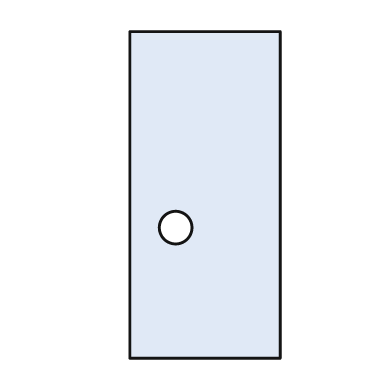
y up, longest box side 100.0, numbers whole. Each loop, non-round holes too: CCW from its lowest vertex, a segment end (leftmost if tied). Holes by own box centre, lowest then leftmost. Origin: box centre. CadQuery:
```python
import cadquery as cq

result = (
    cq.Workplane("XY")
    .moveTo(-23.0, -50.0)
    .lineTo(23.0, -50.0)
    .lineTo(23.0, 50.0)
    .lineTo(-23.0, 50.0)
    .close()
    .moveTo(-9.0, -10.0)
    .circle(5.0)
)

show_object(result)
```